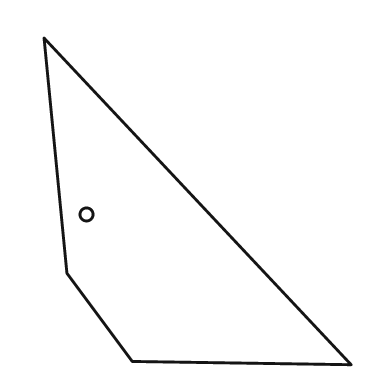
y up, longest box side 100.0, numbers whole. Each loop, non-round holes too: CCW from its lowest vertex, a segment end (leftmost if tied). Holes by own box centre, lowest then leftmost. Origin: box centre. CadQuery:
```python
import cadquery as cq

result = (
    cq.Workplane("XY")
    .moveTo(47.0, -50.0)
    .lineTo(-47.0, 50.0)
    .lineTo(-40.0, -22.0)
    .lineTo(-20.0, -49.0)
    .close()
    .moveTo(-34.0, -4.0)
    .circle(2.0)
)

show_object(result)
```